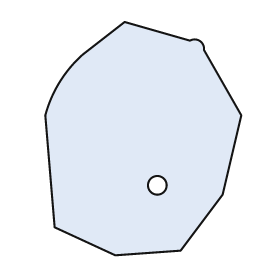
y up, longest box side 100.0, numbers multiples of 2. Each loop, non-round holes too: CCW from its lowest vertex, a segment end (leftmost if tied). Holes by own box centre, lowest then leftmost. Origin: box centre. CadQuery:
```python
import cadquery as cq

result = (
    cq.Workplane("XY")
    .moveTo(-12.0, -50.0)
    .lineTo(16.0, -48.0)
    .lineTo(34.0, -24.0)
    .lineTo(42.0, 10.0)
    .lineTo(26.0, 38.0)
    .threePointArc((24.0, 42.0), (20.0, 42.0))
    .lineTo(-8.0, 50.0)
    .lineTo(-26.0, 36.0)
    .threePointArc((-36.0, 24.0), (-42.0, 10.0))
    .lineTo(-38.0, -38.0)
    .close()
    .moveTo(6.0, -20.0)
    .circle(4.0)
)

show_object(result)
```